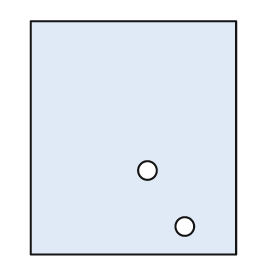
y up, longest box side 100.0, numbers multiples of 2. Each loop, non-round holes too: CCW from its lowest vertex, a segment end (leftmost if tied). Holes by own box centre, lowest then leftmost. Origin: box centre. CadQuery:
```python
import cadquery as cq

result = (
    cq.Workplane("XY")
    .moveTo(-44.0, -50.0)
    .lineTo(44.0, -50.0)
    .lineTo(44.0, 50.0)
    .lineTo(-44.0, 50.0)
    .close()
    .moveTo(22.0, -38.0)
    .circle(4.0)
    .moveTo(6.0, -14.0)
    .circle(4.0)
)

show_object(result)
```